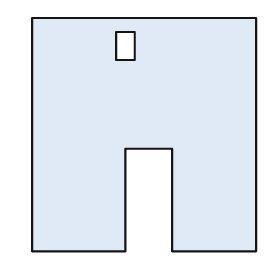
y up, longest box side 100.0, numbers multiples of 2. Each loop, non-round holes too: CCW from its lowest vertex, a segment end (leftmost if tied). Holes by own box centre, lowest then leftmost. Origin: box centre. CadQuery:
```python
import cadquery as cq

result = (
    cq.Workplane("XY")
    .moveTo(-48.0, -50.0)
    .lineTo(-8.0, -50.0)
    .lineTo(-8.0, -6.0)
    .lineTo(12.0, -6.0)
    .lineTo(12.0, -50.0)
    .lineTo(48.0, -50.0)
    .lineTo(48.0, 50.0)
    .lineTo(-48.0, 50.0)
    .close()
    .moveTo(-12.0, 32.0)
    .lineTo(-4.0, 32.0)
    .lineTo(-4.0, 44.0)
    .lineTo(-12.0, 44.0)
    .close()
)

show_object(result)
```